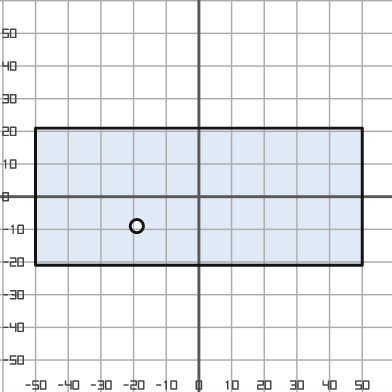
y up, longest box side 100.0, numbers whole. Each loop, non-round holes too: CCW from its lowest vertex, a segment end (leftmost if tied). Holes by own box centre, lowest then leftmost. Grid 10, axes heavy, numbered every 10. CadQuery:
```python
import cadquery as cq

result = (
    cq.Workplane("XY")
    .moveTo(-50.0, -21.0)
    .lineTo(50.0, -21.0)
    .lineTo(50.0, 21.0)
    .lineTo(-50.0, 21.0)
    .close()
    .moveTo(-19.0, -9.0)
    .circle(2.0)
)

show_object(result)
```